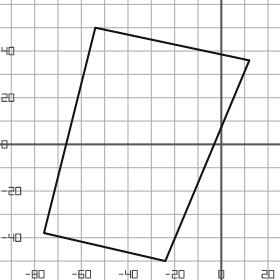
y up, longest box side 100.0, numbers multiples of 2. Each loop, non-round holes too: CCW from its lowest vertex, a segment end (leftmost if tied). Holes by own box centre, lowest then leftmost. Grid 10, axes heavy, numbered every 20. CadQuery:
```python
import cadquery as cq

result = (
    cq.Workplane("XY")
    .moveTo(-24.0, -50.0)
    .lineTo(12.0, 36.0)
    .lineTo(-54.0, 50.0)
    .lineTo(-76.0, -38.0)
    .close()
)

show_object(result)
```